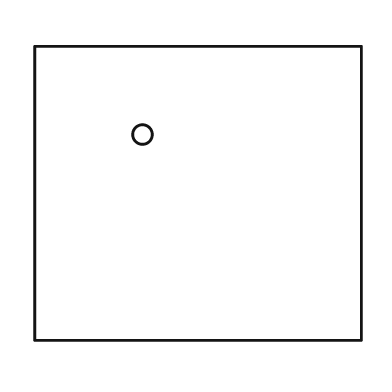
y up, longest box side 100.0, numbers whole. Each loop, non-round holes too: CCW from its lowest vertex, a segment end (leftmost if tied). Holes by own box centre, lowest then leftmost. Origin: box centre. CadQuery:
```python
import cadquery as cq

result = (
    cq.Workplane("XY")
    .moveTo(-50.0, -45.0)
    .lineTo(50.0, -45.0)
    .lineTo(50.0, 45.0)
    .lineTo(-50.0, 45.0)
    .close()
    .moveTo(-17.0, 18.0)
    .circle(3.0)
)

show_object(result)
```